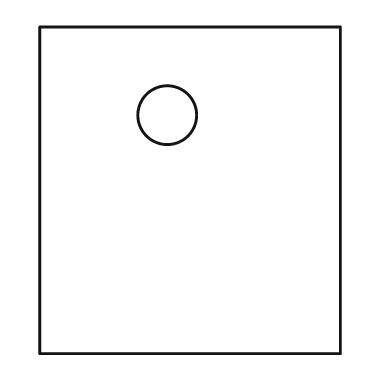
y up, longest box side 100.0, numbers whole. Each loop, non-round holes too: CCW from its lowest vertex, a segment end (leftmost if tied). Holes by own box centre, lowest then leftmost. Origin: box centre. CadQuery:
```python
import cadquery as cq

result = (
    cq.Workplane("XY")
    .moveTo(-46.0, -50.0)
    .lineTo(46.0, -50.0)
    .lineTo(46.0, 50.0)
    .lineTo(-46.0, 50.0)
    .close()
    .moveTo(-7.0, 23.0)
    .circle(9.0)
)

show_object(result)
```